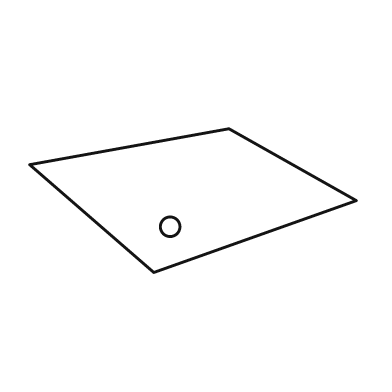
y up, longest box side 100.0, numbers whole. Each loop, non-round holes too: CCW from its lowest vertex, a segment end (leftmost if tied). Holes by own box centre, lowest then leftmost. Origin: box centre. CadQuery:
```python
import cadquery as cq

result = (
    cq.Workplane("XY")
    .moveTo(-12.0, -22.0)
    .lineTo(50.0, 0.0)
    .lineTo(11.0, 22.0)
    .lineTo(-50.0, 11.0)
    .close()
    .moveTo(-7.0, -8.0)
    .circle(3.0)
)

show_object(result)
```